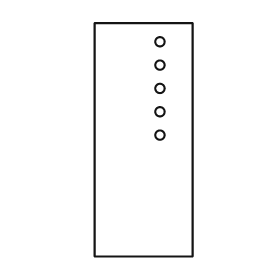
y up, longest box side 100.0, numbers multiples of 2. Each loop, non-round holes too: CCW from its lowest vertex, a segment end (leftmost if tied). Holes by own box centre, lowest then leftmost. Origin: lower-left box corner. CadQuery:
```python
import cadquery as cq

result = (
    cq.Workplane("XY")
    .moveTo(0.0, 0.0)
    .lineTo(42.0, 0.0)
    .lineTo(42.0, 100.0)
    .lineTo(0.0, 100.0)
    .close()
    .moveTo(28.0, 52.0)
    .circle(2.0)
    .moveTo(28.0, 62.0)
    .circle(2.0)
    .moveTo(28.0, 72.0)
    .circle(2.0)
    .moveTo(28.0, 82.0)
    .circle(2.0)
    .moveTo(28.0, 92.0)
    .circle(2.0)
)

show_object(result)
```